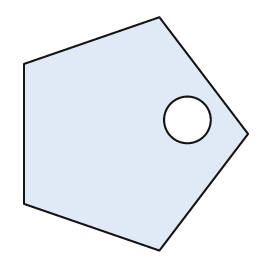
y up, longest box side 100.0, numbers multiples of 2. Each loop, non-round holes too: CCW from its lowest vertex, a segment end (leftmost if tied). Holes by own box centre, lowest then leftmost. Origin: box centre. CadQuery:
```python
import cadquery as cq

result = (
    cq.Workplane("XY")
    .moveTo(10.0, -50.0)
    .lineTo(48.0, 0.0)
    .lineTo(10.0, 50.0)
    .lineTo(-48.0, 30.0)
    .lineTo(-48.0, -30.0)
    .close()
    .moveTo(22.0, 6.0)
    .circle(10.0)
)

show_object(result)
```